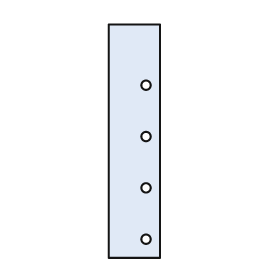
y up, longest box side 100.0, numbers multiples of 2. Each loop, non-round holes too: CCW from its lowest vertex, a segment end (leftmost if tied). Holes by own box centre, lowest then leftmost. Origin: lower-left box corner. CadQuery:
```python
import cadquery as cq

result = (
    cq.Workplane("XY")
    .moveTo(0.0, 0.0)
    .lineTo(22.0, 0.0)
    .lineTo(22.0, 100.0)
    .lineTo(0.0, 100.0)
    .close()
    .moveTo(16.0, 8.0)
    .circle(2.0)
    .moveTo(16.0, 30.0)
    .circle(2.0)
    .moveTo(16.0, 52.0)
    .circle(2.0)
    .moveTo(16.0, 74.0)
    .circle(2.0)
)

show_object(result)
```